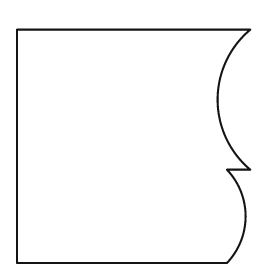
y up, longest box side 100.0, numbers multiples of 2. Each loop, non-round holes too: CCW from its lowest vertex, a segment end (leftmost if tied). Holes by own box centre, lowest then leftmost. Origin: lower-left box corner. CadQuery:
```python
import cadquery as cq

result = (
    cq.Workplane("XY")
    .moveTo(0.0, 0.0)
    .lineTo(90.0, 0.0)
    .threePointArc((98.0, 20.0), (90.0, 40.0))
    .lineTo(100.0, 40.0)
    .threePointArc((86.0, 70.0), (100.0, 100.0))
    .lineTo(0.0, 100.0)
    .close()
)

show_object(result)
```